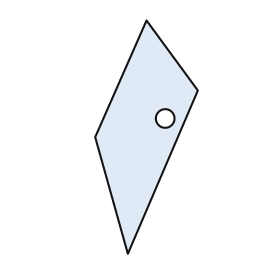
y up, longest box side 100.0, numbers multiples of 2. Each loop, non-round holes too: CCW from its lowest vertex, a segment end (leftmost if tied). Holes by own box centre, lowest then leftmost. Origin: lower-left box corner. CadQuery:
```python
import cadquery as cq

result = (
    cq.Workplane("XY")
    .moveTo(14.0, 0.0)
    .lineTo(44.0, 70.0)
    .lineTo(22.0, 100.0)
    .lineTo(0.0, 50.0)
    .close()
    .moveTo(30.0, 58.0)
    .circle(4.0)
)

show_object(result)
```